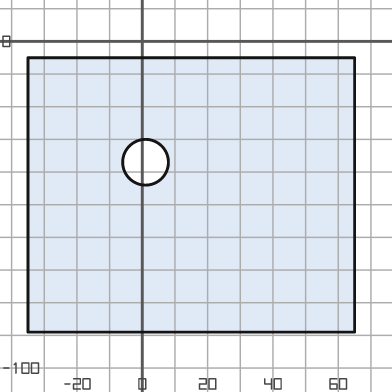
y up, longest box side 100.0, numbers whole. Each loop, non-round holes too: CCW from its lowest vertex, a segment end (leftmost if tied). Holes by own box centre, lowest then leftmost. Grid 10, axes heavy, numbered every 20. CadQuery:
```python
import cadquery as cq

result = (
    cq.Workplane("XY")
    .moveTo(-35.0, -89.0)
    .lineTo(65.0, -89.0)
    .lineTo(65.0, -5.0)
    .lineTo(-35.0, -5.0)
    .close()
    .moveTo(1.0, -37.0)
    .circle(7.0)
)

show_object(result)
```